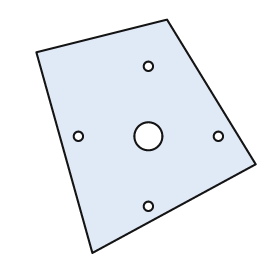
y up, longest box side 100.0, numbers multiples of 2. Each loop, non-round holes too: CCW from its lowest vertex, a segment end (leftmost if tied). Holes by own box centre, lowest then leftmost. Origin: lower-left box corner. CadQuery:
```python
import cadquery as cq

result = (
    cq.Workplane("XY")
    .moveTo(24.0, 0.0)
    .lineTo(94.0, 38.0)
    .lineTo(56.0, 100.0)
    .lineTo(0.0, 86.0)
    .close()
    .moveTo(48.0, 20.0)
    .circle(2.0)
    .moveTo(18.0, 50.0)
    .circle(2.0)
    .moveTo(48.0, 50.0)
    .circle(6.0)
    .moveTo(78.0, 50.0)
    .circle(2.0)
    .moveTo(48.0, 80.0)
    .circle(2.0)
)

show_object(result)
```